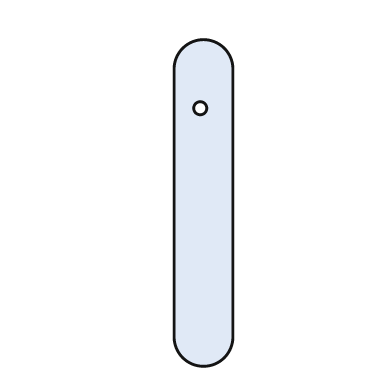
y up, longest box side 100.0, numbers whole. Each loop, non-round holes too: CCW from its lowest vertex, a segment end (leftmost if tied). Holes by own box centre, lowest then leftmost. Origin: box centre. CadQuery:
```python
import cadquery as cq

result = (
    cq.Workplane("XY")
    .moveTo(-9.0, -41.0)
    .threePointArc((0.0, -50.0), (9.0, -41.0))
    .lineTo(9.0, 41.0)
    .threePointArc((0.0, 50.0), (-9.0, 41.0))
    .close()
    .moveTo(-1.0, 29.0)
    .circle(2.0)
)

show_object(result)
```